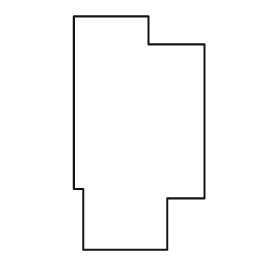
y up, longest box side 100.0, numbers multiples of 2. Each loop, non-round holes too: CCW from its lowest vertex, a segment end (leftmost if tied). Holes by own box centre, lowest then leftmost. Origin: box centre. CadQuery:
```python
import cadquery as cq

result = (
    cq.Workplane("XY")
    .moveTo(-24.0, -50.0)
    .lineTo(12.0, -50.0)
    .lineTo(12.0, -28.0)
    .lineTo(28.0, -28.0)
    .lineTo(28.0, 38.0)
    .lineTo(4.0, 38.0)
    .lineTo(4.0, 50.0)
    .lineTo(-28.0, 50.0)
    .lineTo(-28.0, -24.0)
    .lineTo(-24.0, -24.0)
    .close()
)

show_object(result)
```